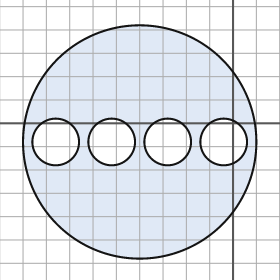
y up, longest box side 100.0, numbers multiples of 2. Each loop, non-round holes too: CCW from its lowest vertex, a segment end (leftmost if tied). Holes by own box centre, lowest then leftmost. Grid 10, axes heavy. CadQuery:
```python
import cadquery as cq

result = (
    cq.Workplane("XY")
    .moveTo(-40.0, -8.0)
    .circle(50.0)
    .moveTo(-76.0, -8.0)
    .circle(10.0)
    .moveTo(-52.0, -8.0)
    .circle(10.0)
    .moveTo(-28.0, -8.0)
    .circle(10.0)
    .moveTo(-4.0, -8.0)
    .circle(10.0)
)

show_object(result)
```